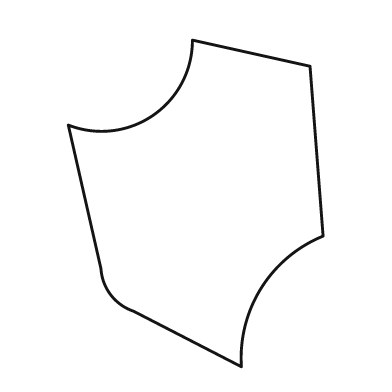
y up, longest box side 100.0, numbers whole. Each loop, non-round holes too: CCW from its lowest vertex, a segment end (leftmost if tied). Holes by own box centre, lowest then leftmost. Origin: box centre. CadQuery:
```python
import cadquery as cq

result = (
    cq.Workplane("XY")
    .moveTo(14.0, -50.0)
    .threePointArc((20.0, -26.0), (39.0, -10.0))
    .lineTo(35.0, 42.0)
    .lineTo(-1.0, 50.0)
    .threePointArc((-13.0, 27.0), (-39.0, 24.0))
    .lineTo(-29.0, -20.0)
    .threePointArc((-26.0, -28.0), (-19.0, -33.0))
    .close()
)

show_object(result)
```